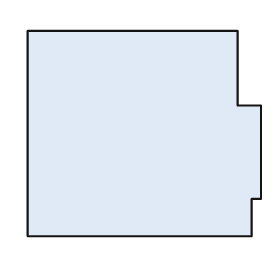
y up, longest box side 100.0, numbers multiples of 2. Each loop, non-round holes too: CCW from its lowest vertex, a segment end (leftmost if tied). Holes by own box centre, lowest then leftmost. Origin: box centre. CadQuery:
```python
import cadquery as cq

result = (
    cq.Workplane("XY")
    .moveTo(-50.0, -44.0)
    .lineTo(46.0, -44.0)
    .lineTo(46.0, -28.0)
    .lineTo(50.0, -28.0)
    .lineTo(50.0, 12.0)
    .lineTo(40.0, 12.0)
    .lineTo(40.0, 44.0)
    .lineTo(-50.0, 44.0)
    .close()
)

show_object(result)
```